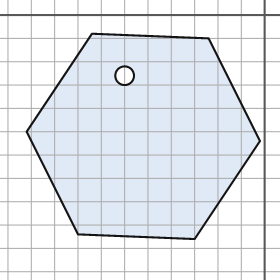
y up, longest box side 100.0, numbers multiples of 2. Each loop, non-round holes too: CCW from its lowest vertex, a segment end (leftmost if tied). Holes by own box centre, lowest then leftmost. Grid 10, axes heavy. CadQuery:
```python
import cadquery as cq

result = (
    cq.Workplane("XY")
    .moveTo(-30.0, -96.0)
    .lineTo(-2.0, -54.0)
    .lineTo(-24.0, -10.0)
    .lineTo(-74.0, -8.0)
    .lineTo(-102.0, -50.0)
    .lineTo(-80.0, -94.0)
    .close()
    .moveTo(-60.0, -26.0)
    .circle(4.0)
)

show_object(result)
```